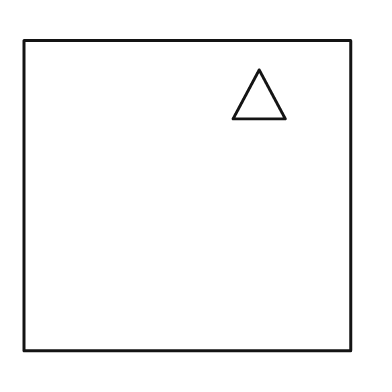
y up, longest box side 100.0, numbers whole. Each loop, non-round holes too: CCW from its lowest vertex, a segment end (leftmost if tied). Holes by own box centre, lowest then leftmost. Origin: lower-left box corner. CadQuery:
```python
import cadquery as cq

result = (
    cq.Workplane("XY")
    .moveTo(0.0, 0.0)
    .lineTo(100.0, 0.0)
    .lineTo(100.0, 95.0)
    .lineTo(0.0, 95.0)
    .close()
    .moveTo(64.0, 71.0)
    .lineTo(80.0, 71.0)
    .lineTo(72.0, 86.0)
    .close()
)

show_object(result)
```